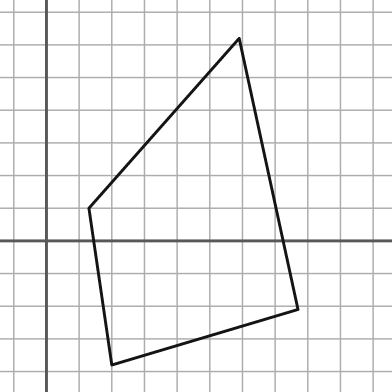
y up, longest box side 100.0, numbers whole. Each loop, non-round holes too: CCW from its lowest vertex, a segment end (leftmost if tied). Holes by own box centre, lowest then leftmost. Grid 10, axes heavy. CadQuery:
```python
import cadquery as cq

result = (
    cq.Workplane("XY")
    .moveTo(20.0, -38.0)
    .lineTo(77.0, -21.0)
    .lineTo(59.0, 62.0)
    .lineTo(13.0, 10.0)
    .close()
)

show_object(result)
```